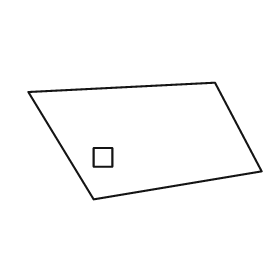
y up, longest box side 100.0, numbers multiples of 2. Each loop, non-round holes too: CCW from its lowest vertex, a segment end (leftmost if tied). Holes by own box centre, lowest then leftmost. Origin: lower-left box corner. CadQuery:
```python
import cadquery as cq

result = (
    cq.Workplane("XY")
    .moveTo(28.0, 0.0)
    .lineTo(100.0, 12.0)
    .lineTo(80.0, 50.0)
    .lineTo(0.0, 46.0)
    .close()
    .moveTo(28.0, 14.0)
    .lineTo(36.0, 14.0)
    .lineTo(36.0, 22.0)
    .lineTo(28.0, 22.0)
    .close()
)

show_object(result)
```